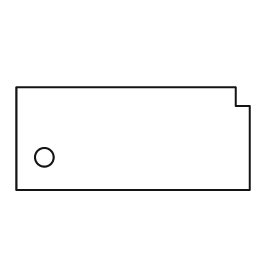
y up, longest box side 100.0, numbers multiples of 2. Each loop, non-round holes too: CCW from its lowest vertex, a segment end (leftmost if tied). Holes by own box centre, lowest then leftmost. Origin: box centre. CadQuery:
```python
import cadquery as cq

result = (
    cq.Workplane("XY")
    .moveTo(-50.0, -22.0)
    .lineTo(50.0, -22.0)
    .lineTo(50.0, 14.0)
    .lineTo(44.0, 14.0)
    .lineTo(44.0, 22.0)
    .lineTo(-50.0, 22.0)
    .close()
    .moveTo(-38.0, -8.0)
    .circle(4.0)
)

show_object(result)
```